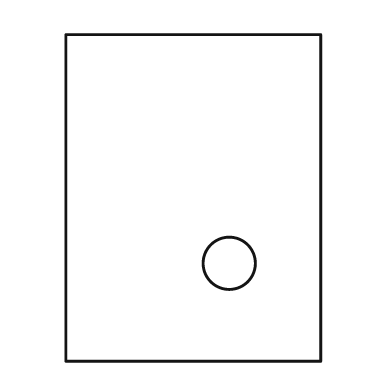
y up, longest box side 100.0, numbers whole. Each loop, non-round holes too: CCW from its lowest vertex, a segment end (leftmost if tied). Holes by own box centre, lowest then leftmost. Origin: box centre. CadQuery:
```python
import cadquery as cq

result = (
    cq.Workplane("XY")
    .moveTo(-39.0, -50.0)
    .lineTo(39.0, -50.0)
    .lineTo(39.0, 50.0)
    .lineTo(-39.0, 50.0)
    .close()
    .moveTo(11.0, -20.0)
    .circle(8.0)
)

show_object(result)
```